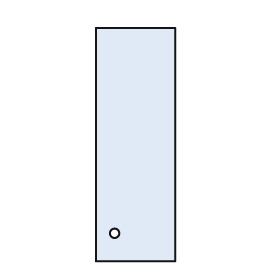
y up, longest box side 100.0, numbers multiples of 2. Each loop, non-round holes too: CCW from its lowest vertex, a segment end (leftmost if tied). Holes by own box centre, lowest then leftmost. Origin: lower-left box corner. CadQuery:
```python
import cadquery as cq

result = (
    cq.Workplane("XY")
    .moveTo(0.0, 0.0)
    .lineTo(34.0, 0.0)
    .lineTo(34.0, 100.0)
    .lineTo(0.0, 100.0)
    .close()
    .moveTo(8.0, 12.0)
    .circle(2.0)
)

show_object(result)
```